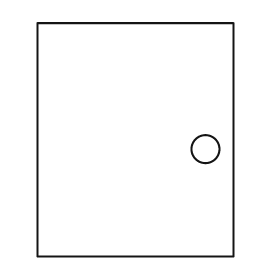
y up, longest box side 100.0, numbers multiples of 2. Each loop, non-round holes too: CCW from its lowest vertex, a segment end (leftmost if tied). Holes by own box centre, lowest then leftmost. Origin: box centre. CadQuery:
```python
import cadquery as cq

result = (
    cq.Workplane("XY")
    .moveTo(-42.0, -50.0)
    .lineTo(42.0, -50.0)
    .lineTo(42.0, 50.0)
    .lineTo(-42.0, 50.0)
    .close()
    .moveTo(30.0, -4.0)
    .circle(6.0)
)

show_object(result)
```